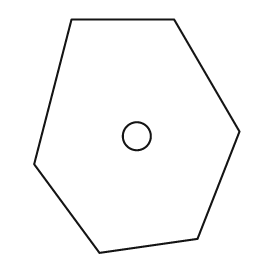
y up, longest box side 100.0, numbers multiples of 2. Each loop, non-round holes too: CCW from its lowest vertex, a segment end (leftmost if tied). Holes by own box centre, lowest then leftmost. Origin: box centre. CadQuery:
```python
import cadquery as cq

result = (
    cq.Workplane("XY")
    .moveTo(-16.0, -50.0)
    .lineTo(26.0, -44.0)
    .lineTo(44.0, 2.0)
    .lineTo(16.0, 50.0)
    .lineTo(-28.0, 50.0)
    .lineTo(-44.0, -12.0)
    .close()
    .moveTo(0.0, 0.0)
    .circle(6.0)
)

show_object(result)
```